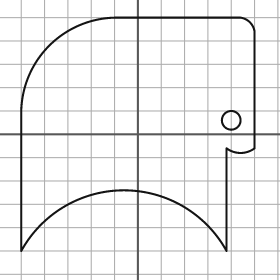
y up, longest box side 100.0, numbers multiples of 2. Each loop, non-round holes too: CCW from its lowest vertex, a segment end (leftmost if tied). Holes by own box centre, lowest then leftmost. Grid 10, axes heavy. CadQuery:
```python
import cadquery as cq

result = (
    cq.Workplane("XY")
    .moveTo(-50.0, -50.0)
    .threePointArc((-6.0, -24.0), (38.0, -50.0))
    .lineTo(38.0, -6.0)
    .threePointArc((44.0, -8.0), (50.0, -6.0))
    .lineTo(50.0, 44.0)
    .threePointArc((48.0, 48.0), (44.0, 50.0))
    .lineTo(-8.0, 50.0)
    .threePointArc((-38.0, 38.0), (-50.0, 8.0))
    .close()
    .moveTo(40.0, 6.0)
    .circle(4.0)
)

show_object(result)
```